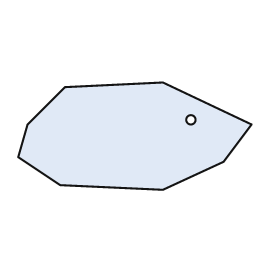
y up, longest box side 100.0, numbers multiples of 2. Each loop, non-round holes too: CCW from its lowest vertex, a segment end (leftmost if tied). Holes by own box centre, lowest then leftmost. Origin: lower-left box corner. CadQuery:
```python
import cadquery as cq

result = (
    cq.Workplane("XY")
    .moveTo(62.0, 0.0)
    .lineTo(88.0, 12.0)
    .lineTo(100.0, 28.0)
    .lineTo(62.0, 46.0)
    .lineTo(20.0, 44.0)
    .lineTo(4.0, 28.0)
    .lineTo(0.0, 14.0)
    .lineTo(18.0, 2.0)
    .close()
    .moveTo(74.0, 30.0)
    .circle(2.0)
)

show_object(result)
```